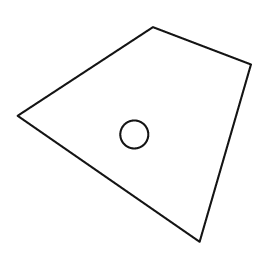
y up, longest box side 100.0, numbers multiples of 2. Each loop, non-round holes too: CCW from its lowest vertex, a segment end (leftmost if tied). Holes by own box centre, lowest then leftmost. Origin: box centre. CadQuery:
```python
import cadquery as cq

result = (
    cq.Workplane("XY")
    .moveTo(28.0, -46.0)
    .lineTo(50.0, 30.0)
    .lineTo(8.0, 46.0)
    .lineTo(-50.0, 8.0)
    .close()
    .moveTo(0.0, 0.0)
    .circle(6.0)
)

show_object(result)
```